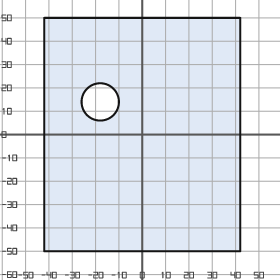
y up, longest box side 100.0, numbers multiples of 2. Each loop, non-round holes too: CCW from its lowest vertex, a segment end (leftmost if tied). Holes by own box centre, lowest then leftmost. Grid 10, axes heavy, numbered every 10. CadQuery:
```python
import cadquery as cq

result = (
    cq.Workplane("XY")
    .moveTo(-42.0, -50.0)
    .lineTo(42.0, -50.0)
    .lineTo(42.0, 50.0)
    .lineTo(-42.0, 50.0)
    .close()
    .moveTo(-18.0, 14.0)
    .circle(8.0)
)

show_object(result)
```